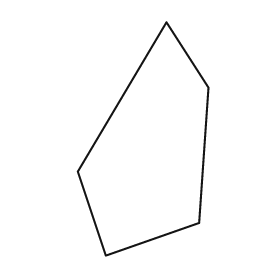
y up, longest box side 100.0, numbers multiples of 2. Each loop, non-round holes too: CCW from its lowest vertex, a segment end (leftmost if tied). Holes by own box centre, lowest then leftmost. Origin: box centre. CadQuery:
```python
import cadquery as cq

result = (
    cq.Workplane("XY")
    .moveTo(-16.0, -50.0)
    .lineTo(24.0, -36.0)
    .lineTo(28.0, 22.0)
    .lineTo(10.0, 50.0)
    .lineTo(-28.0, -14.0)
    .close()
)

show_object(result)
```